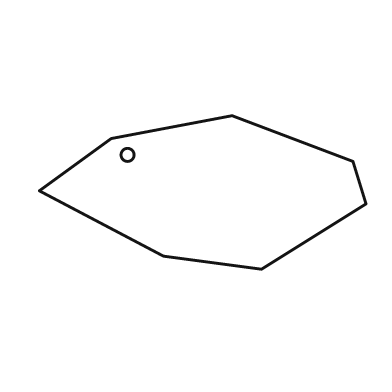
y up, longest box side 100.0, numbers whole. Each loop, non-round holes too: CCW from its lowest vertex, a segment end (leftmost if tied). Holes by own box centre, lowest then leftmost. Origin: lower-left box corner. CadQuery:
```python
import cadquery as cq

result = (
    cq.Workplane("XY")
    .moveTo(68.0, 0.0)
    .lineTo(100.0, 20.0)
    .lineTo(96.0, 33.0)
    .lineTo(59.0, 47.0)
    .lineTo(22.0, 40.0)
    .lineTo(0.0, 24.0)
    .lineTo(38.0, 4.0)
    .close()
    .moveTo(27.0, 35.0)
    .circle(2.0)
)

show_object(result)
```